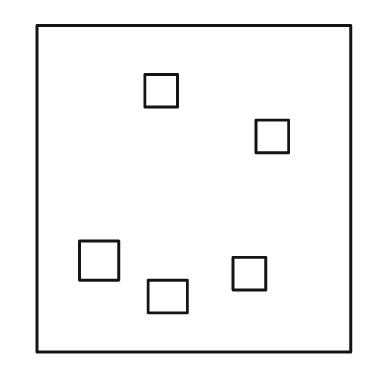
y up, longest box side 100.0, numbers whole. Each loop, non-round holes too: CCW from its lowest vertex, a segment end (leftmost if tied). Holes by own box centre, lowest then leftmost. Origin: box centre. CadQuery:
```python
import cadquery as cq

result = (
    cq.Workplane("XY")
    .moveTo(-48.0, -50.0)
    .lineTo(48.0, -50.0)
    .lineTo(48.0, 50.0)
    .lineTo(-48.0, 50.0)
    .close()
    .moveTo(-14.0, -38.0)
    .lineTo(-2.0, -38.0)
    .lineTo(-2.0, -28.0)
    .lineTo(-14.0, -28.0)
    .close()
    .moveTo(12.0, -31.0)
    .lineTo(22.0, -31.0)
    .lineTo(22.0, -21.0)
    .lineTo(12.0, -21.0)
    .close()
    .moveTo(-35.0, -28.0)
    .lineTo(-23.0, -28.0)
    .lineTo(-23.0, -16.0)
    .lineTo(-35.0, -16.0)
    .close()
    .moveTo(19.0, 11.0)
    .lineTo(29.0, 11.0)
    .lineTo(29.0, 21.0)
    .lineTo(19.0, 21.0)
    .close()
    .moveTo(-15.0, 25.0)
    .lineTo(-5.0, 25.0)
    .lineTo(-5.0, 35.0)
    .lineTo(-15.0, 35.0)
    .close()
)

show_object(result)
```